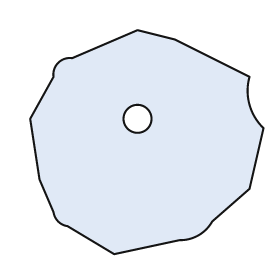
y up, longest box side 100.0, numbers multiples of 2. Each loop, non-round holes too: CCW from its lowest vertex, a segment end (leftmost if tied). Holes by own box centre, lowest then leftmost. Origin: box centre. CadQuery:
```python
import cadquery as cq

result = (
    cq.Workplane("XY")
    .moveTo(-14.0, -48.0)
    .lineTo(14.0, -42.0)
    .threePointArc((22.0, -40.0), (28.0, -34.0))
    .lineTo(44.0, -20.0)
    .lineTo(50.0, 6.0)
    .threePointArc((44.0, 16.0), (44.0, 28.0))
    .lineTo(12.0, 44.0)
    .lineTo(-4.0, 48.0)
    .lineTo(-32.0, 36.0)
    .threePointArc((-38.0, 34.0), (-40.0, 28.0))
    .lineTo(-50.0, 10.0)
    .lineTo(-46.0, -16.0)
    .lineTo(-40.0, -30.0)
    .threePointArc((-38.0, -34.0), (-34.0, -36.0))
    .close()
    .moveTo(-4.0, 10.0)
    .circle(6.0)
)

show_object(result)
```